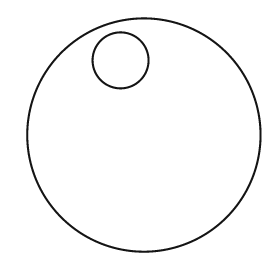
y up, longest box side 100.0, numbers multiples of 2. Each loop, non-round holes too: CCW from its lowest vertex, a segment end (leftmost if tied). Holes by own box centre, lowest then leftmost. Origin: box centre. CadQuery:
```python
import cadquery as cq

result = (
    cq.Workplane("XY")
    .moveTo(0.0, 0.0)
    .circle(50.0)
    .moveTo(-10.0, 32.0)
    .circle(12.0)
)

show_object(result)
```